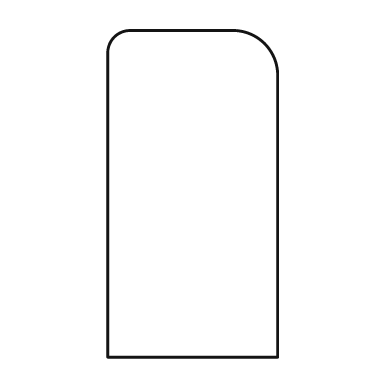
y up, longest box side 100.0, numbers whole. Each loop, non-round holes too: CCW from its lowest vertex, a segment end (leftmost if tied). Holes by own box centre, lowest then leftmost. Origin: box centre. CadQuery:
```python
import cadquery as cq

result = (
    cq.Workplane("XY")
    .moveTo(-26.0, -50.0)
    .lineTo(26.0, -50.0)
    .lineTo(26.0, 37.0)
    .threePointArc((22.0, 46.0), (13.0, 50.0))
    .lineTo(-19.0, 50.0)
    .threePointArc((-24.0, 48.0), (-26.0, 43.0))
    .close()
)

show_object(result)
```